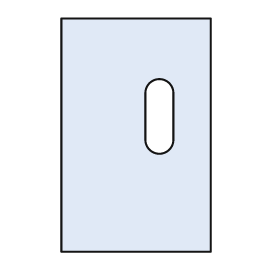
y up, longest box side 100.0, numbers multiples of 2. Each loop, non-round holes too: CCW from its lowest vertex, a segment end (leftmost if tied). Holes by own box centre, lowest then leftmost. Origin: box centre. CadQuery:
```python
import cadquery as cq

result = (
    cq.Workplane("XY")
    .moveTo(-32.0, -50.0)
    .lineTo(32.0, -50.0)
    .lineTo(32.0, 50.0)
    .lineTo(-32.0, 50.0)
    .close()
    .moveTo(4.0, -2.0)
    .threePointArc((10.0, -8.0), (16.0, -2.0))
    .lineTo(16.0, 18.0)
    .threePointArc((10.0, 24.0), (4.0, 18.0))
    .close()
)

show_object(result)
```